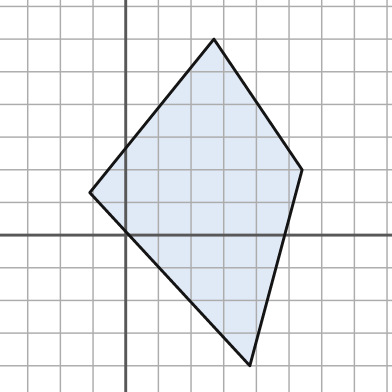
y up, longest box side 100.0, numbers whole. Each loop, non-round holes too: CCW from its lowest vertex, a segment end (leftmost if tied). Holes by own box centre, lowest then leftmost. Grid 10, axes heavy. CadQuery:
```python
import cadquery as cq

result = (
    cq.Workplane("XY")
    .moveTo(38.0, -40.0)
    .lineTo(54.0, 20.0)
    .lineTo(27.0, 60.0)
    .lineTo(-11.0, 13.0)
    .close()
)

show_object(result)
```